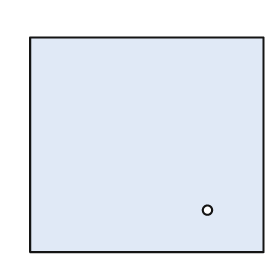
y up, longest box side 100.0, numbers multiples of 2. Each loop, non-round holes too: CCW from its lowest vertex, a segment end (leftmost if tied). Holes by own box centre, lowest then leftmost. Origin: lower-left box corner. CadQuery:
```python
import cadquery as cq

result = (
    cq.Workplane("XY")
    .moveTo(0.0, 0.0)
    .lineTo(100.0, 0.0)
    .lineTo(100.0, 92.0)
    .lineTo(0.0, 92.0)
    .close()
    .moveTo(76.0, 18.0)
    .circle(2.0)
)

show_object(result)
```